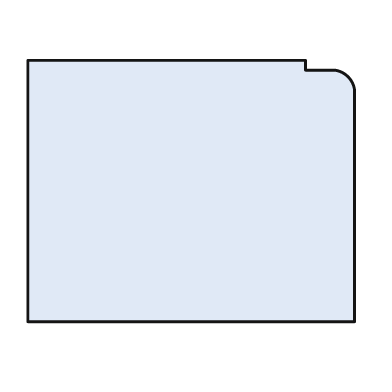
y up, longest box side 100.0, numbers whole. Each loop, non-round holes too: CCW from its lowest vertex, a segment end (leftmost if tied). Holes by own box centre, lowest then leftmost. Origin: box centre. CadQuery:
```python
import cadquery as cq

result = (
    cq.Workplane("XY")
    .moveTo(-50.0, -40.0)
    .lineTo(50.0, -40.0)
    .lineTo(50.0, 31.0)
    .threePointArc((48.0, 35.0), (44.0, 37.0))
    .lineTo(35.0, 37.0)
    .lineTo(35.0, 40.0)
    .lineTo(-50.0, 40.0)
    .close()
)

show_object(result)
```